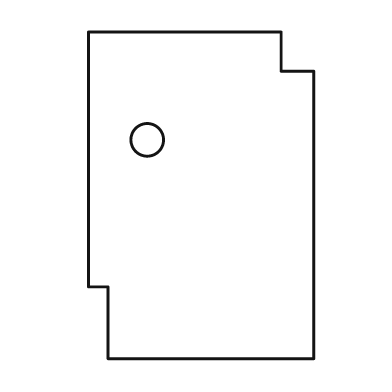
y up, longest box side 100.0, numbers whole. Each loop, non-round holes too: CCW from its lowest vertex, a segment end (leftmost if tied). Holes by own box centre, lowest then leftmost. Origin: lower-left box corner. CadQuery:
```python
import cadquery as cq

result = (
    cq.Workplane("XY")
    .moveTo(6.0, 0.0)
    .lineTo(69.0, 0.0)
    .lineTo(69.0, 88.0)
    .lineTo(59.0, 88.0)
    .lineTo(59.0, 100.0)
    .lineTo(0.0, 100.0)
    .lineTo(0.0, 22.0)
    .lineTo(6.0, 22.0)
    .close()
    .moveTo(18.0, 67.0)
    .circle(5.0)
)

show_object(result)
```